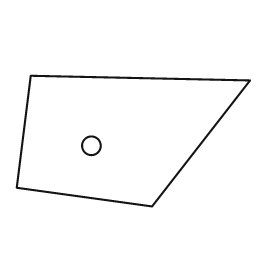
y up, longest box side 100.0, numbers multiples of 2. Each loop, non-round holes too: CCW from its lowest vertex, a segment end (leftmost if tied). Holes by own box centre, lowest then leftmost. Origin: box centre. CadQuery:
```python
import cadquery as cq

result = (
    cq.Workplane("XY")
    .moveTo(8.0, -28.0)
    .lineTo(50.0, 26.0)
    .lineTo(-44.0, 28.0)
    .lineTo(-50.0, -20.0)
    .close()
    .moveTo(-18.0, -2.0)
    .circle(4.0)
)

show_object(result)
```